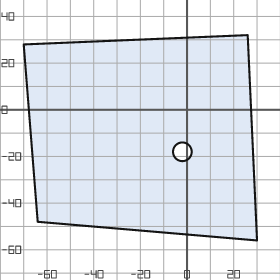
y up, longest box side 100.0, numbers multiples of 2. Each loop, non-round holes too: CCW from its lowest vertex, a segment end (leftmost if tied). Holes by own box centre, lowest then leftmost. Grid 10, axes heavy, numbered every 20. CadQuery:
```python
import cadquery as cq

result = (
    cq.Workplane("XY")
    .moveTo(30.0, -56.0)
    .lineTo(26.0, 32.0)
    .lineTo(-70.0, 28.0)
    .lineTo(-64.0, -48.0)
    .close()
    .moveTo(-2.0, -18.0)
    .circle(4.0)
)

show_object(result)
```